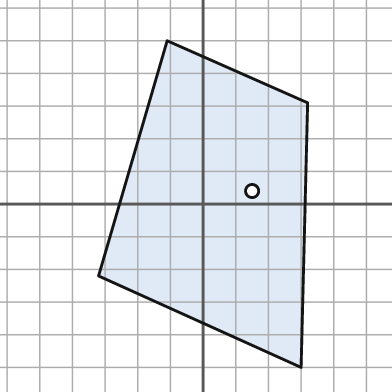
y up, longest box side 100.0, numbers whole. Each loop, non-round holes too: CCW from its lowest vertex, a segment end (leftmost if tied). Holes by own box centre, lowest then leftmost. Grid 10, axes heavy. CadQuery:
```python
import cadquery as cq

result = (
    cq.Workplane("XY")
    .moveTo(30.0, -50.0)
    .lineTo(32.0, 31.0)
    .lineTo(-11.0, 50.0)
    .lineTo(-32.0, -22.0)
    .close()
    .moveTo(15.0, 4.0)
    .circle(2.0)
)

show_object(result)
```